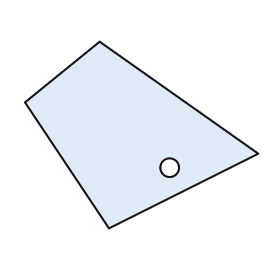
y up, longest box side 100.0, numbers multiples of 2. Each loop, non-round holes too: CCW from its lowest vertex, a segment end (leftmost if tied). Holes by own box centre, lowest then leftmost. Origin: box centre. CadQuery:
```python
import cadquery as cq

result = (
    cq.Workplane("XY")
    .moveTo(-14.0, -40.0)
    .lineTo(50.0, -8.0)
    .lineTo(-18.0, 40.0)
    .lineTo(-50.0, 14.0)
    .close()
    .moveTo(12.0, -14.0)
    .circle(4.0)
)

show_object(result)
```